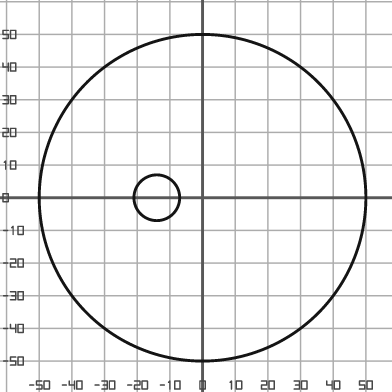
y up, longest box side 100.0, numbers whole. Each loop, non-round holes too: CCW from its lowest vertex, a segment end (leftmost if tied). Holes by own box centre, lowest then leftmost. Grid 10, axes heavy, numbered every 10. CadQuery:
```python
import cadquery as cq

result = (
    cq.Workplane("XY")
    .moveTo(0.0, 0.0)
    .circle(50.0)
    .moveTo(-14.0, 0.0)
    .circle(7.0)
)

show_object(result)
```